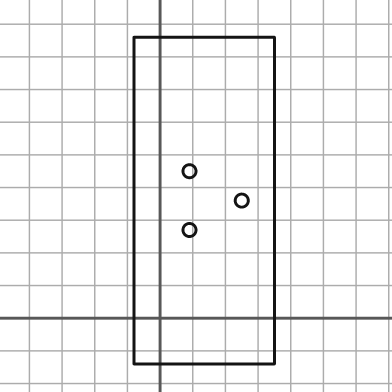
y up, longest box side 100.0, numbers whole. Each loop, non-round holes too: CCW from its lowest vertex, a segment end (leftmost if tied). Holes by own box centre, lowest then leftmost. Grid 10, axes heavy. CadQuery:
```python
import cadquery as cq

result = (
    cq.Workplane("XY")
    .moveTo(-8.0, -14.0)
    .lineTo(35.0, -14.0)
    .lineTo(35.0, 86.0)
    .lineTo(-8.0, 86.0)
    .close()
    .moveTo(9.0, 27.0)
    .circle(2.0)
    .moveTo(25.0, 36.0)
    .circle(2.0)
    .moveTo(9.0, 45.0)
    .circle(2.0)
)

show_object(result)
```